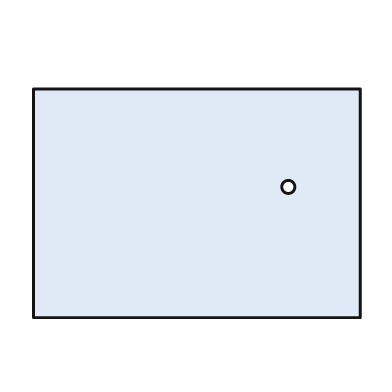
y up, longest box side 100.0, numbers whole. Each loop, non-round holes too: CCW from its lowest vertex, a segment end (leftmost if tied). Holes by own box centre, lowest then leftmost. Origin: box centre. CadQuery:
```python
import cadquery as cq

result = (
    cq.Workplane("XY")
    .moveTo(-50.0, -35.0)
    .lineTo(50.0, -35.0)
    .lineTo(50.0, 35.0)
    .lineTo(-50.0, 35.0)
    .close()
    .moveTo(28.0, 5.0)
    .circle(2.0)
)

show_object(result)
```